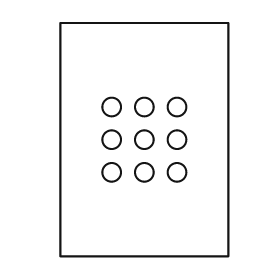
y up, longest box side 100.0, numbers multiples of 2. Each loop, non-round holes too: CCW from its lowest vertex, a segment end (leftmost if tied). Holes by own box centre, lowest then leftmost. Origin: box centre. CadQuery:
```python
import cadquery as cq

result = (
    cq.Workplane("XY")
    .moveTo(-36.0, -50.0)
    .lineTo(36.0, -50.0)
    .lineTo(36.0, 50.0)
    .lineTo(-36.0, 50.0)
    .close()
    .moveTo(-14.0, -14.0)
    .circle(4.0)
    .moveTo(0.0, -14.0)
    .circle(4.0)
    .moveTo(14.0, -14.0)
    .circle(4.0)
    .moveTo(-14.0, 0.0)
    .circle(4.0)
    .moveTo(0.0, 0.0)
    .circle(4.0)
    .moveTo(14.0, 0.0)
    .circle(4.0)
    .moveTo(-14.0, 14.0)
    .circle(4.0)
    .moveTo(0.0, 14.0)
    .circle(4.0)
    .moveTo(14.0, 14.0)
    .circle(4.0)
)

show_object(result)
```